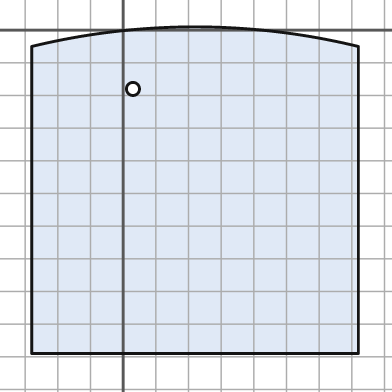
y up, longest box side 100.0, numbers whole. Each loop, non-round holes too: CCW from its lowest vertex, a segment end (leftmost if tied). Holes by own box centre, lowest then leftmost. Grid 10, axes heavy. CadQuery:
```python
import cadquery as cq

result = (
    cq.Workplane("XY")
    .moveTo(-28.0, -99.0)
    .lineTo(72.0, -99.0)
    .lineTo(72.0, -5.0)
    .threePointArc((22.0, 1.0), (-28.0, -5.0))
    .close()
    .moveTo(3.0, -18.0)
    .circle(2.0)
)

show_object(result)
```